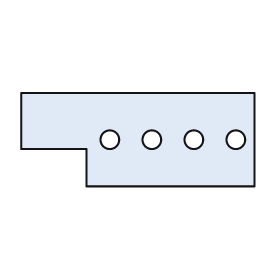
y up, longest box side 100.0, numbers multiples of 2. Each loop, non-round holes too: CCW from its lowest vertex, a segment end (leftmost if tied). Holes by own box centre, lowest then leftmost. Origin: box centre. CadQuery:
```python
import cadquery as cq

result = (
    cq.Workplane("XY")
    .moveTo(-22.0, -20.0)
    .lineTo(50.0, -20.0)
    .lineTo(50.0, 20.0)
    .lineTo(-50.0, 20.0)
    .lineTo(-50.0, -4.0)
    .lineTo(-22.0, -4.0)
    .close()
    .moveTo(-12.0, 0.0)
    .circle(4.0)
    .moveTo(6.0, 0.0)
    .circle(4.0)
    .moveTo(24.0, 0.0)
    .circle(4.0)
    .moveTo(42.0, 0.0)
    .circle(4.0)
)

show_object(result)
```